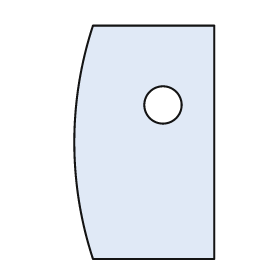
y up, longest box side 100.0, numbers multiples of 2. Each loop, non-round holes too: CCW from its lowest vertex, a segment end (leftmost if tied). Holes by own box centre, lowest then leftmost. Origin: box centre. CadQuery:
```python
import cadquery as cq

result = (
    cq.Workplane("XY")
    .moveTo(-22.0, -50.0)
    .lineTo(30.0, -50.0)
    .lineTo(30.0, 50.0)
    .lineTo(-22.0, 50.0)
    .threePointArc((-30.0, 0.0), (-22.0, -50.0))
    .close()
    .moveTo(8.0, 16.0)
    .circle(8.0)
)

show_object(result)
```